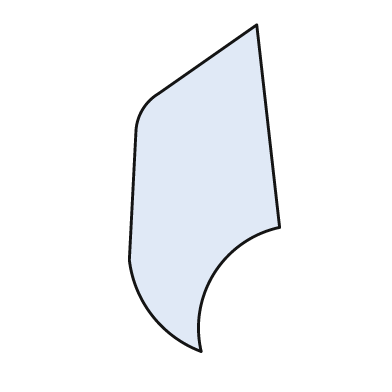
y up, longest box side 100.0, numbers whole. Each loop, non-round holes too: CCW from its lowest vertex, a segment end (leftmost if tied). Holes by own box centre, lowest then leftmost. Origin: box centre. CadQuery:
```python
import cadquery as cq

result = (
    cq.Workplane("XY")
    .moveTo(-1.0, -50.0)
    .threePointArc((3.0, -26.0), (23.0, -12.0))
    .lineTo(16.0, 50.0)
    .lineTo(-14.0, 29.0)
    .threePointArc((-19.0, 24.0), (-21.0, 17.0))
    .lineTo(-23.0, -22.0)
    .threePointArc((-16.0, -39.0), (-1.0, -50.0))
    .close()
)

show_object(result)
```